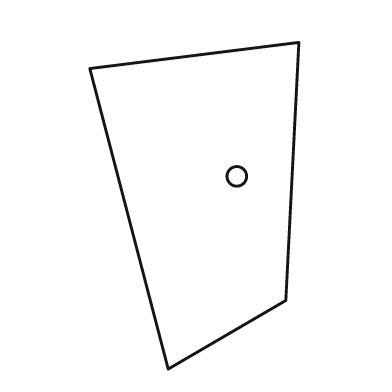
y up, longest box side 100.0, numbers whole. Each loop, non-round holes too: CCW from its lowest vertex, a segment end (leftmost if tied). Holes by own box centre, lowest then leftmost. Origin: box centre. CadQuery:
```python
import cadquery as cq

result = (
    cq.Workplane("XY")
    .moveTo(-8.0, -50.0)
    .lineTo(28.0, -29.0)
    .lineTo(32.0, 50.0)
    .lineTo(-32.0, 42.0)
    .close()
    .moveTo(13.0, 9.0)
    .circle(3.0)
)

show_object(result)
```